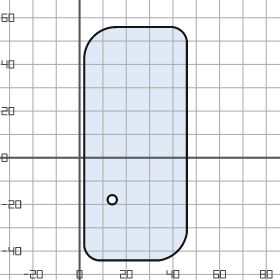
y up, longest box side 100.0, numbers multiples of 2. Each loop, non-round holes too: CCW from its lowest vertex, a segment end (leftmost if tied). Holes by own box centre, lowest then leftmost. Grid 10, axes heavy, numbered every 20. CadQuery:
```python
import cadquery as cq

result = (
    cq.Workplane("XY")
    .moveTo(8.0, -44.0)
    .lineTo(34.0, -44.0)
    .threePointArc((42.0, -40.0), (46.0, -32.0))
    .lineTo(46.0, 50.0)
    .threePointArc((44.0, 54.0), (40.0, 56.0))
    .lineTo(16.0, 56.0)
    .threePointArc((6.0, 52.0), (2.0, 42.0))
    .lineTo(2.0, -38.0)
    .threePointArc((4.0, -42.0), (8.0, -44.0))
    .close()
    .moveTo(14.0, -18.0)
    .circle(2.0)
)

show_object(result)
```